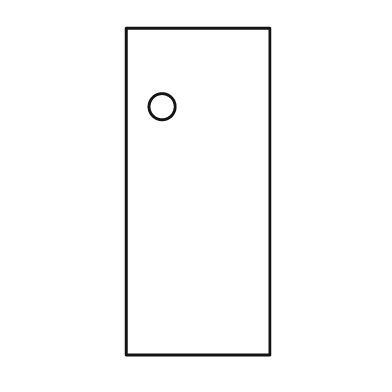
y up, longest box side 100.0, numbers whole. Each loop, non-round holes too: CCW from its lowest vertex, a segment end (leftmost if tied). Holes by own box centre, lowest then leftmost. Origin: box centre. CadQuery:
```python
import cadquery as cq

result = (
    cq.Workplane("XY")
    .moveTo(-22.0, -50.0)
    .lineTo(22.0, -50.0)
    .lineTo(22.0, 50.0)
    .lineTo(-22.0, 50.0)
    .close()
    .moveTo(-11.0, 26.0)
    .circle(4.0)
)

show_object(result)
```